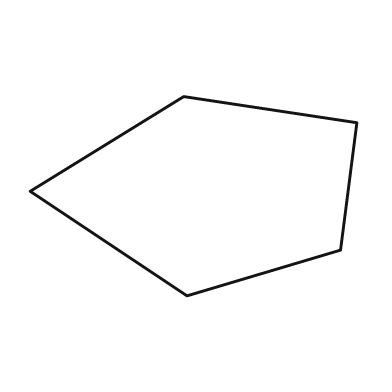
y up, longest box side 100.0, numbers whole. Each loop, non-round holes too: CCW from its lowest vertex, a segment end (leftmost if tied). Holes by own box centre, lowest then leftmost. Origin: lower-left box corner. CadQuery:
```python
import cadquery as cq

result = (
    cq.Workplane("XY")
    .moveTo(48.0, 0.0)
    .lineTo(95.0, 14.0)
    .lineTo(100.0, 53.0)
    .lineTo(47.0, 61.0)
    .lineTo(0.0, 32.0)
    .close()
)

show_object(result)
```